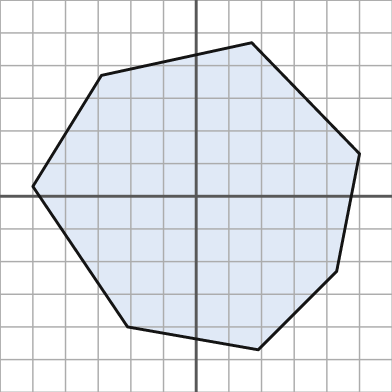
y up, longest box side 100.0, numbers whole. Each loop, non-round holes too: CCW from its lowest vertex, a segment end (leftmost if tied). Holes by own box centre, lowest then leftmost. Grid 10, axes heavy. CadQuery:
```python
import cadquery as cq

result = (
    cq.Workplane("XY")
    .moveTo(19.0, -47.0)
    .lineTo(43.0, -23.0)
    .lineTo(50.0, 13.0)
    .lineTo(17.0, 47.0)
    .lineTo(-29.0, 37.0)
    .lineTo(-50.0, 3.0)
    .lineTo(-21.0, -40.0)
    .close()
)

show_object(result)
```